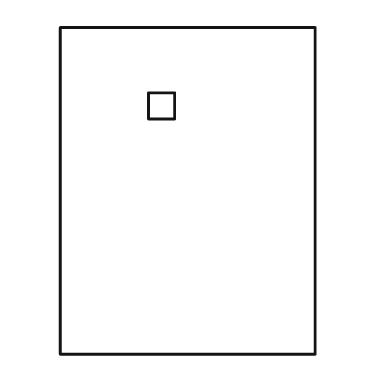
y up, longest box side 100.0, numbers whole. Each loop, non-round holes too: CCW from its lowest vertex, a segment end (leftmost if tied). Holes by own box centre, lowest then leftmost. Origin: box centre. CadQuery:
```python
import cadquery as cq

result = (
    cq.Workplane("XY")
    .moveTo(-39.0, -50.0)
    .lineTo(39.0, -50.0)
    .lineTo(39.0, 50.0)
    .lineTo(-39.0, 50.0)
    .close()
    .moveTo(-12.0, 22.0)
    .lineTo(-4.0, 22.0)
    .lineTo(-4.0, 30.0)
    .lineTo(-12.0, 30.0)
    .close()
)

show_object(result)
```